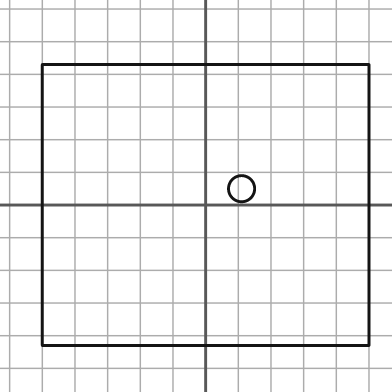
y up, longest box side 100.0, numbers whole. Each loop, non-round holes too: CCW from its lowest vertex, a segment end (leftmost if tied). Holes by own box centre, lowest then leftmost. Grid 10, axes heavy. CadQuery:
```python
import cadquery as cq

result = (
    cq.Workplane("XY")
    .moveTo(-50.0, -43.0)
    .lineTo(50.0, -43.0)
    .lineTo(50.0, 43.0)
    .lineTo(-50.0, 43.0)
    .close()
    .moveTo(11.0, 5.0)
    .circle(4.0)
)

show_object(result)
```